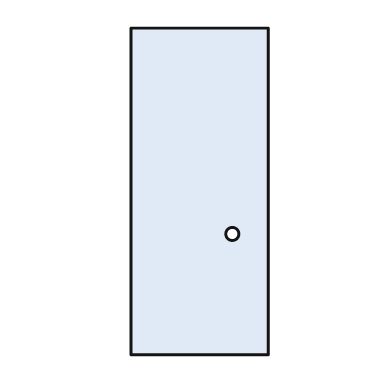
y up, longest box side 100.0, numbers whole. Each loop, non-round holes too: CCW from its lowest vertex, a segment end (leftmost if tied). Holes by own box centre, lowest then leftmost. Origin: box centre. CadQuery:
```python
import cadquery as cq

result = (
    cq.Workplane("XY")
    .moveTo(-21.0, -50.0)
    .lineTo(21.0, -50.0)
    .lineTo(21.0, 50.0)
    .lineTo(-21.0, 50.0)
    .close()
    .moveTo(10.0, -13.0)
    .circle(2.0)
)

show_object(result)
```